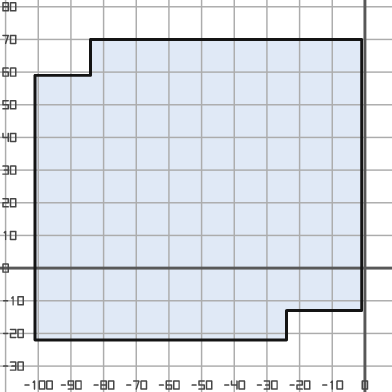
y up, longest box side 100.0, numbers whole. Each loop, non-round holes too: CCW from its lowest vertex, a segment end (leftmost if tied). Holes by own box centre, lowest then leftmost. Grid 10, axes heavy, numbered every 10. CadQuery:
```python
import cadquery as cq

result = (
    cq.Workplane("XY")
    .moveTo(-101.0, -22.0)
    .lineTo(-24.0, -22.0)
    .lineTo(-24.0, -13.0)
    .lineTo(-1.0, -13.0)
    .lineTo(-1.0, 70.0)
    .lineTo(-84.0, 70.0)
    .lineTo(-84.0, 59.0)
    .lineTo(-101.0, 59.0)
    .close()
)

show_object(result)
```